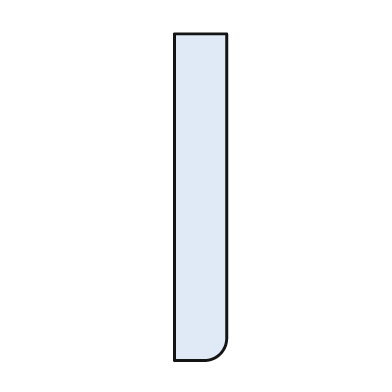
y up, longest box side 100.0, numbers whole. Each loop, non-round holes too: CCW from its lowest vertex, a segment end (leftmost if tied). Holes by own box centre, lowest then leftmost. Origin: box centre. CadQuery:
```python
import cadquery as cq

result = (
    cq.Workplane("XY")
    .moveTo(-8.0, -50.0)
    .lineTo(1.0, -50.0)
    .threePointArc((6.0, -48.0), (8.0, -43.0))
    .lineTo(8.0, 50.0)
    .lineTo(-8.0, 50.0)
    .close()
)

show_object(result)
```